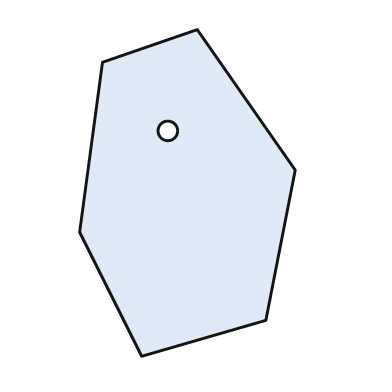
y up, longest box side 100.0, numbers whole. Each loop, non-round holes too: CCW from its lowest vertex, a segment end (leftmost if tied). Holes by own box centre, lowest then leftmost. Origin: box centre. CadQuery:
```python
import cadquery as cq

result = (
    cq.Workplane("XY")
    .moveTo(-14.0, -50.0)
    .lineTo(24.0, -39.0)
    .lineTo(33.0, 7.0)
    .lineTo(3.0, 50.0)
    .lineTo(-26.0, 40.0)
    .lineTo(-33.0, -12.0)
    .close()
    .moveTo(-6.0, 19.0)
    .circle(3.0)
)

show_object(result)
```